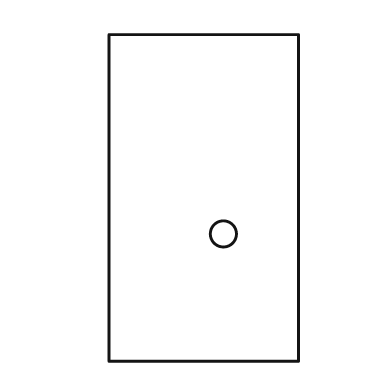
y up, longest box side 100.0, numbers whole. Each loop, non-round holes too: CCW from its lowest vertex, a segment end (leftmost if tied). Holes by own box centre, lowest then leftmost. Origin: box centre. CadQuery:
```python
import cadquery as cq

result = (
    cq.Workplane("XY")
    .moveTo(-29.0, -50.0)
    .lineTo(29.0, -50.0)
    .lineTo(29.0, 50.0)
    .lineTo(-29.0, 50.0)
    .close()
    .moveTo(6.0, -11.0)
    .circle(4.0)
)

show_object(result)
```